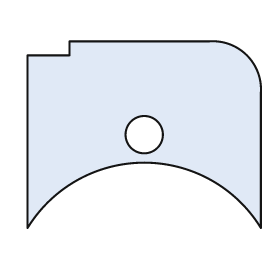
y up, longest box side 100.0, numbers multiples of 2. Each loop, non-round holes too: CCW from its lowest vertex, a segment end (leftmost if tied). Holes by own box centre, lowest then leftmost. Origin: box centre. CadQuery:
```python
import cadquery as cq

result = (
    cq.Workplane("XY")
    .moveTo(-50.0, -40.0)
    .threePointArc((0.0, -12.0), (50.0, -40.0))
    .lineTo(50.0, 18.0)
    .threePointArc((44.0, 34.0), (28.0, 40.0))
    .lineTo(-32.0, 40.0)
    .lineTo(-32.0, 34.0)
    .lineTo(-50.0, 34.0)
    .close()
    .moveTo(0.0, 0.0)
    .circle(8.0)
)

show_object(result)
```